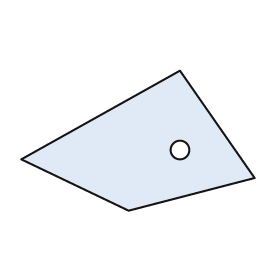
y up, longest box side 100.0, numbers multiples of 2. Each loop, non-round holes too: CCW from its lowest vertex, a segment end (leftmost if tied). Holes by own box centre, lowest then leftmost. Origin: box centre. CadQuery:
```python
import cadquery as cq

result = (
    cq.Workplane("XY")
    .moveTo(-4.0, -30.0)
    .lineTo(50.0, -16.0)
    .lineTo(18.0, 30.0)
    .lineTo(-50.0, -8.0)
    .close()
    .moveTo(18.0, -4.0)
    .circle(4.0)
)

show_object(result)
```